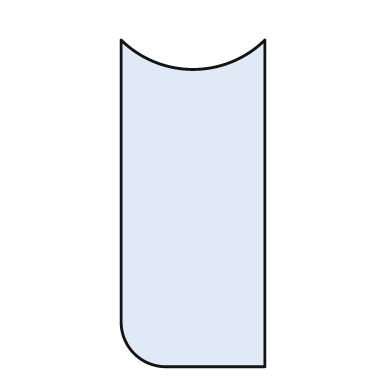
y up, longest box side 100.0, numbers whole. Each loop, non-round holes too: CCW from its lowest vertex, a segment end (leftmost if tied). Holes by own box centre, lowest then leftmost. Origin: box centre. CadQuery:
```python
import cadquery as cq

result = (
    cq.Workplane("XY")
    .moveTo(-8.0, -50.0)
    .lineTo(22.0, -50.0)
    .lineTo(22.0, 50.0)
    .threePointArc((0.0, 41.0), (-22.0, 50.0))
    .lineTo(-22.0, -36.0)
    .threePointArc((-18.0, -46.0), (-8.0, -50.0))
    .close()
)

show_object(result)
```